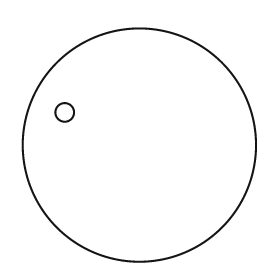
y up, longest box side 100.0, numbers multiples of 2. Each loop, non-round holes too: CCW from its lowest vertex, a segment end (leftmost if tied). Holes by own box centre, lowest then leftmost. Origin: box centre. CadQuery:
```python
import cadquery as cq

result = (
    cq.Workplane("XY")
    .moveTo(0.0, 0.0)
    .circle(50.0)
    .moveTo(-32.0, 14.0)
    .circle(4.0)
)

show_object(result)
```